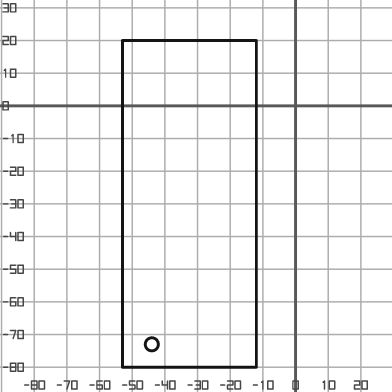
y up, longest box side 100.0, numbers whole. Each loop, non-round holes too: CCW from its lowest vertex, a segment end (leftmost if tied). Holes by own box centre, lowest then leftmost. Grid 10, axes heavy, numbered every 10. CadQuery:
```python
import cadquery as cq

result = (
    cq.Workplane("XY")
    .moveTo(-53.0, -80.0)
    .lineTo(-12.0, -80.0)
    .lineTo(-12.0, 20.0)
    .lineTo(-53.0, 20.0)
    .close()
    .moveTo(-44.0, -73.0)
    .circle(2.0)
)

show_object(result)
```